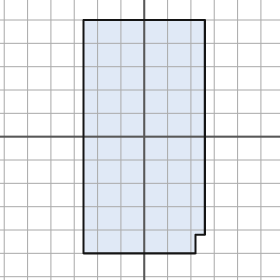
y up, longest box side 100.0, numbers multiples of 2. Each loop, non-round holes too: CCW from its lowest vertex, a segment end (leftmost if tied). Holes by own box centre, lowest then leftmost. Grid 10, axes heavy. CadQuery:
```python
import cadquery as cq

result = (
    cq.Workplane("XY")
    .moveTo(-26.0, -50.0)
    .lineTo(22.0, -50.0)
    .lineTo(22.0, -42.0)
    .lineTo(26.0, -42.0)
    .lineTo(26.0, 50.0)
    .lineTo(-26.0, 50.0)
    .close()
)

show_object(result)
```